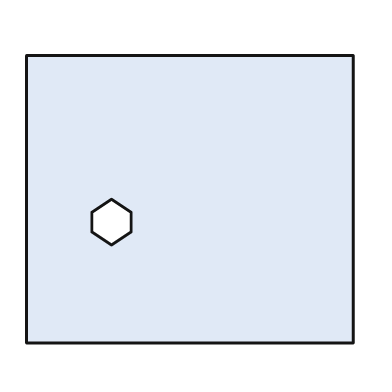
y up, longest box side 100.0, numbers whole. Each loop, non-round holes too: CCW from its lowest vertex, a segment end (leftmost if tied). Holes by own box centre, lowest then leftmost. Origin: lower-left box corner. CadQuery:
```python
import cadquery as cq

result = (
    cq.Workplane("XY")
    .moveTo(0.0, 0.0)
    .lineTo(100.0, 0.0)
    .lineTo(100.0, 88.0)
    .lineTo(0.0, 88.0)
    .close()
    .moveTo(26.0, 30.0)
    .lineTo(32.0, 34.0)
    .lineTo(32.0, 40.0)
    .lineTo(26.0, 44.0)
    .lineTo(20.0, 40.0)
    .lineTo(20.0, 34.0)
    .close()
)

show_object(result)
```